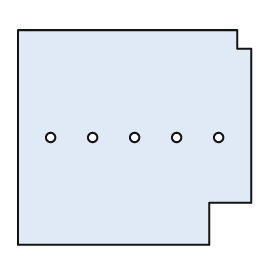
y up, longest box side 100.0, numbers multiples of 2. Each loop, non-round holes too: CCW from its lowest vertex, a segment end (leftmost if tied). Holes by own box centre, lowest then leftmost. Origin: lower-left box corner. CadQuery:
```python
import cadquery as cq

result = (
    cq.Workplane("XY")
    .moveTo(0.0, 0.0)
    .lineTo(82.0, 0.0)
    .lineTo(82.0, 18.0)
    .lineTo(100.0, 18.0)
    .lineTo(100.0, 84.0)
    .lineTo(94.0, 84.0)
    .lineTo(94.0, 92.0)
    .lineTo(0.0, 92.0)
    .close()
    .moveTo(14.0, 46.0)
    .circle(2.0)
    .moveTo(32.0, 46.0)
    .circle(2.0)
    .moveTo(50.0, 46.0)
    .circle(2.0)
    .moveTo(68.0, 46.0)
    .circle(2.0)
    .moveTo(86.0, 46.0)
    .circle(2.0)
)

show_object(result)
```